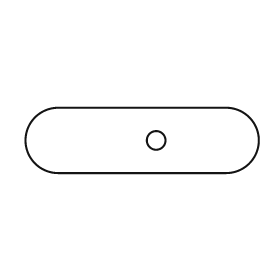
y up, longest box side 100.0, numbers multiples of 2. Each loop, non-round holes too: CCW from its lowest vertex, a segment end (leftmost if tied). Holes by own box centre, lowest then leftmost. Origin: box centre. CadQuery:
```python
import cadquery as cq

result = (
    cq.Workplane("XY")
    .moveTo(-36.0, -14.0)
    .lineTo(36.0, -14.0)
    .threePointArc((50.0, 0.0), (36.0, 14.0))
    .lineTo(-36.0, 14.0)
    .threePointArc((-50.0, 0.0), (-36.0, -14.0))
    .close()
    .moveTo(6.0, 0.0)
    .circle(4.0)
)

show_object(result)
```